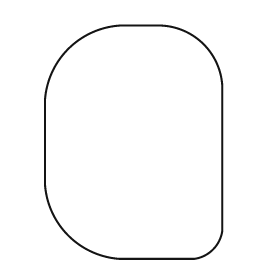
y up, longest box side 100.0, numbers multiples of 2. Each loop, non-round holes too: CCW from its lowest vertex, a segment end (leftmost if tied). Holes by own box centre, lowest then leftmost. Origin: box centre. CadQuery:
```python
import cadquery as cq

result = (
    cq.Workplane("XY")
    .moveTo(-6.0, -50.0)
    .lineTo(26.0, -50.0)
    .threePointArc((34.0, -46.0), (38.0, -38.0))
    .lineTo(38.0, 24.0)
    .threePointArc((30.0, 42.0), (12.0, 50.0))
    .lineTo(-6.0, 50.0)
    .threePointArc((-28.0, 40.0), (-38.0, 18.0))
    .lineTo(-38.0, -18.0)
    .threePointArc((-28.0, -40.0), (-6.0, -50.0))
    .close()
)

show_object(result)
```